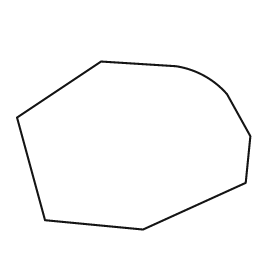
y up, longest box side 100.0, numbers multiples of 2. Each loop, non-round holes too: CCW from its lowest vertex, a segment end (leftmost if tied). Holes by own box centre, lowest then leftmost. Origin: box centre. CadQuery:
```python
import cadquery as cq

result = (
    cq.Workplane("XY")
    .moveTo(4.0, -36.0)
    .lineTo(48.0, -16.0)
    .lineTo(50.0, 4.0)
    .lineTo(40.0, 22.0)
    .threePointArc((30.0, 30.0), (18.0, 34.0))
    .lineTo(-14.0, 36.0)
    .lineTo(-50.0, 12.0)
    .lineTo(-38.0, -32.0)
    .close()
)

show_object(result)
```